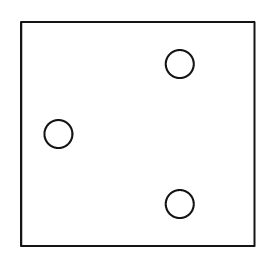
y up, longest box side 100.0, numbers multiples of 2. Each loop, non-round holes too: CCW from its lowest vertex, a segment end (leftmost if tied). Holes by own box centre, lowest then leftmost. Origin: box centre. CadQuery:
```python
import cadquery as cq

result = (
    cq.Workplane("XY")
    .moveTo(-50.0, -48.0)
    .lineTo(50.0, -48.0)
    .lineTo(50.0, 48.0)
    .lineTo(-50.0, 48.0)
    .close()
    .moveTo(18.0, -30.0)
    .circle(6.0)
    .moveTo(-34.0, 0.0)
    .circle(6.0)
    .moveTo(18.0, 30.0)
    .circle(6.0)
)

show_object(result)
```